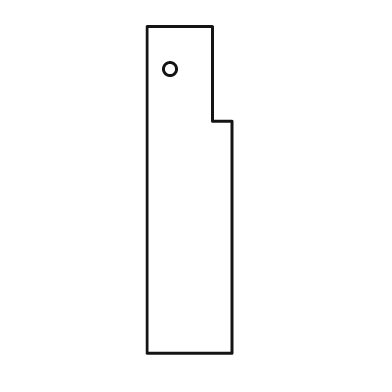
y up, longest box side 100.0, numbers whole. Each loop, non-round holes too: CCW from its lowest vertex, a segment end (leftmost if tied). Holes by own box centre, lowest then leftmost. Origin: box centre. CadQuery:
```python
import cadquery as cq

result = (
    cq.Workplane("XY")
    .moveTo(-13.0, -50.0)
    .lineTo(13.0, -50.0)
    .lineTo(13.0, 21.0)
    .lineTo(7.0, 21.0)
    .lineTo(7.0, 50.0)
    .lineTo(-13.0, 50.0)
    .close()
    .moveTo(-6.0, 37.0)
    .circle(2.0)
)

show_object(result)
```